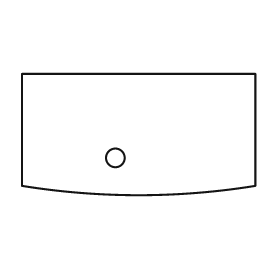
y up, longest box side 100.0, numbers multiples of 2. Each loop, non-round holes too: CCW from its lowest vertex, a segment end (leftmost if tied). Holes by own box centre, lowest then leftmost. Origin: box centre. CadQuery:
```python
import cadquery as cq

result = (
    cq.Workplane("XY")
    .moveTo(-50.0, -22.0)
    .threePointArc((0.0, -26.0), (50.0, -22.0))
    .lineTo(50.0, 26.0)
    .lineTo(-50.0, 26.0)
    .close()
    .moveTo(-10.0, -10.0)
    .circle(4.0)
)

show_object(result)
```